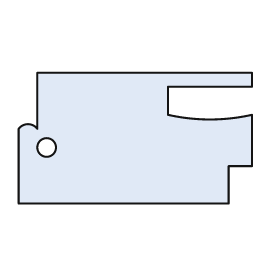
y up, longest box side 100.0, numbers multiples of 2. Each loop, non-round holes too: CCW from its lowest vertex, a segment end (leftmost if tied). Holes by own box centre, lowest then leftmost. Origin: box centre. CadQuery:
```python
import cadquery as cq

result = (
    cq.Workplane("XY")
    .moveTo(-50.0, -28.0)
    .lineTo(40.0, -28.0)
    .lineTo(40.0, -12.0)
    .lineTo(50.0, -12.0)
    .lineTo(50.0, 10.0)
    .threePointArc((32.0, 8.0), (14.0, 10.0))
    .lineTo(14.0, 22.0)
    .lineTo(50.0, 22.0)
    .lineTo(50.0, 28.0)
    .lineTo(-42.0, 28.0)
    .lineTo(-42.0, 4.0)
    .threePointArc((-46.0, 6.0), (-50.0, 4.0))
    .close()
    .moveTo(-38.0, -4.0)
    .circle(4.0)
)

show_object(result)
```